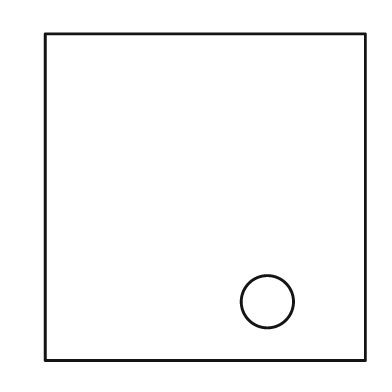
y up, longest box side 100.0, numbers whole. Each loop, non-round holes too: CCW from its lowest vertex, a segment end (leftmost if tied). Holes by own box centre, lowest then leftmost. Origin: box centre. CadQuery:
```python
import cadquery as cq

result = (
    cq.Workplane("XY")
    .moveTo(-49.0, -50.0)
    .lineTo(49.0, -50.0)
    .lineTo(49.0, 50.0)
    .lineTo(-49.0, 50.0)
    .close()
    .moveTo(19.0, -32.0)
    .circle(8.0)
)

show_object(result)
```